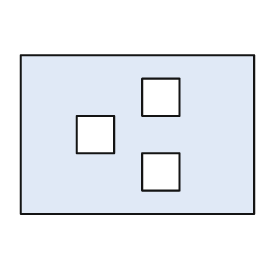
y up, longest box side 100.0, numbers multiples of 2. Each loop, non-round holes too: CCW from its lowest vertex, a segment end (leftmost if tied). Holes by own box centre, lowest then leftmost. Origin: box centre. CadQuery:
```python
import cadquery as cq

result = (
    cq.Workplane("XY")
    .moveTo(-50.0, -34.0)
    .lineTo(50.0, -34.0)
    .lineTo(50.0, 34.0)
    .lineTo(-50.0, 34.0)
    .close()
    .moveTo(2.0, -24.0)
    .lineTo(18.0, -24.0)
    .lineTo(18.0, -8.0)
    .lineTo(2.0, -8.0)
    .close()
    .moveTo(-26.0, -8.0)
    .lineTo(-10.0, -8.0)
    .lineTo(-10.0, 8.0)
    .lineTo(-26.0, 8.0)
    .close()
    .moveTo(2.0, 8.0)
    .lineTo(18.0, 8.0)
    .lineTo(18.0, 24.0)
    .lineTo(2.0, 24.0)
    .close()
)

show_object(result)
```